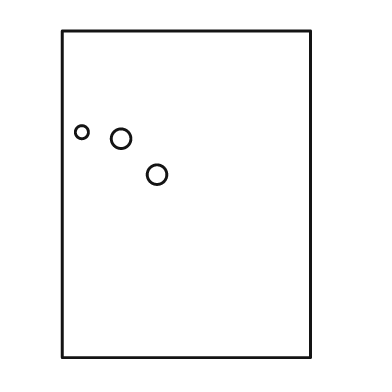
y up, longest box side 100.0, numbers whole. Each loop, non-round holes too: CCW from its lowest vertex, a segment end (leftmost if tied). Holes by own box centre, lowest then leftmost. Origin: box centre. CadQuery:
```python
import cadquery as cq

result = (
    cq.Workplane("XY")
    .moveTo(-38.0, -50.0)
    .lineTo(38.0, -50.0)
    .lineTo(38.0, 50.0)
    .lineTo(-38.0, 50.0)
    .close()
    .moveTo(-9.0, 6.0)
    .circle(3.0)
    .moveTo(-20.0, 17.0)
    .circle(3.0)
    .moveTo(-32.0, 19.0)
    .circle(2.0)
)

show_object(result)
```